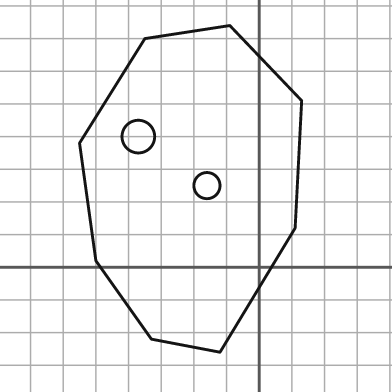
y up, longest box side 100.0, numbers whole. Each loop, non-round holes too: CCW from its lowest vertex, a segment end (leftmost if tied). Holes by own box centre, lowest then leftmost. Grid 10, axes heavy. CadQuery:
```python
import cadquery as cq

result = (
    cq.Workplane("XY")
    .moveTo(-12.0, -26.0)
    .lineTo(11.0, 12.0)
    .lineTo(13.0, 51.0)
    .lineTo(-9.0, 74.0)
    .lineTo(-35.0, 70.0)
    .lineTo(-55.0, 38.0)
    .lineTo(-50.0, 2.0)
    .lineTo(-33.0, -22.0)
    .close()
    .moveTo(-16.0, 25.0)
    .circle(4.0)
    .moveTo(-37.0, 40.0)
    .circle(5.0)
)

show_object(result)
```